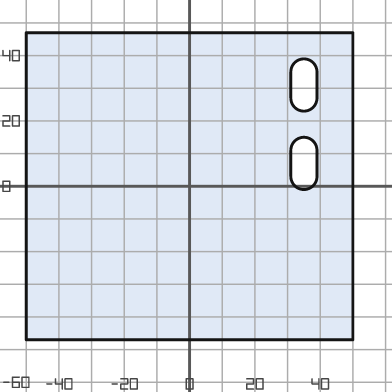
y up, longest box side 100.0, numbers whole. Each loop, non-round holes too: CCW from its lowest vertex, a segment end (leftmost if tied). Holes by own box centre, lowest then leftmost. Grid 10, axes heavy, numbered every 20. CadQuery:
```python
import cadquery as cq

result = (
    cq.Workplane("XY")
    .moveTo(-50.0, -47.0)
    .lineTo(50.0, -47.0)
    .lineTo(50.0, 47.0)
    .lineTo(-50.0, 47.0)
    .close()
    .moveTo(31.0, 3.0)
    .threePointArc((35.0, -1.0), (39.0, 3.0))
    .lineTo(39.0, 11.0)
    .threePointArc((35.0, 15.0), (31.0, 11.0))
    .close()
    .moveTo(31.0, 27.0)
    .threePointArc((35.0, 23.0), (39.0, 27.0))
    .lineTo(39.0, 35.0)
    .threePointArc((35.0, 39.0), (31.0, 35.0))
    .close()
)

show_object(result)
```